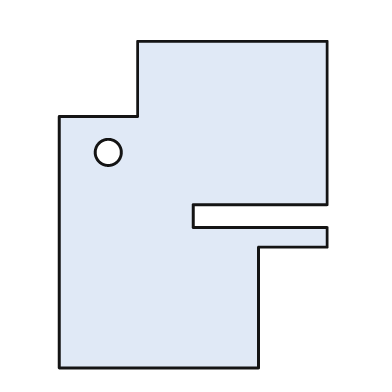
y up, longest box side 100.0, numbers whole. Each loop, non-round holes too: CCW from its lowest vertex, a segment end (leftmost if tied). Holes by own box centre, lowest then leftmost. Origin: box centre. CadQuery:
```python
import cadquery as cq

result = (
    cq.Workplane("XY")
    .moveTo(-41.0, -50.0)
    .lineTo(20.0, -50.0)
    .lineTo(20.0, -13.0)
    .lineTo(41.0, -13.0)
    .lineTo(41.0, -7.0)
    .lineTo(0.0, -7.0)
    .lineTo(0.0, 0.0)
    .lineTo(41.0, 0.0)
    .lineTo(41.0, 50.0)
    .lineTo(-17.0, 50.0)
    .lineTo(-17.0, 27.0)
    .lineTo(-41.0, 27.0)
    .close()
    .moveTo(-26.0, 16.0)
    .circle(4.0)
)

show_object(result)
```